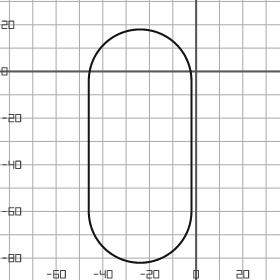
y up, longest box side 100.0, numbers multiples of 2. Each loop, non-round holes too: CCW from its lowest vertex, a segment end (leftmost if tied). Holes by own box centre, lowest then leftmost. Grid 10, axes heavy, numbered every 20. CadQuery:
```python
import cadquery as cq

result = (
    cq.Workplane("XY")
    .moveTo(-46.0, -60.0)
    .threePointArc((-24.0, -82.0), (-2.0, -60.0))
    .lineTo(-2.0, -4.0)
    .threePointArc((-24.0, 18.0), (-46.0, -4.0))
    .close()
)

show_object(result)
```